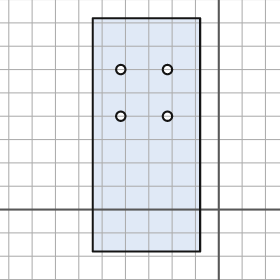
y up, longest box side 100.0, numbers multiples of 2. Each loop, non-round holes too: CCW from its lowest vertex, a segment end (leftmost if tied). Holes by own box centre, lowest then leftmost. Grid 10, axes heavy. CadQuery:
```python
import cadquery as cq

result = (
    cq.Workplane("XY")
    .moveTo(-54.0, -18.0)
    .lineTo(-8.0, -18.0)
    .lineTo(-8.0, 82.0)
    .lineTo(-54.0, 82.0)
    .close()
    .moveTo(-42.0, 40.0)
    .circle(2.0)
    .moveTo(-22.0, 40.0)
    .circle(2.0)
    .moveTo(-42.0, 60.0)
    .circle(2.0)
    .moveTo(-22.0, 60.0)
    .circle(2.0)
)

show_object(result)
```